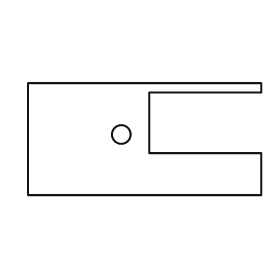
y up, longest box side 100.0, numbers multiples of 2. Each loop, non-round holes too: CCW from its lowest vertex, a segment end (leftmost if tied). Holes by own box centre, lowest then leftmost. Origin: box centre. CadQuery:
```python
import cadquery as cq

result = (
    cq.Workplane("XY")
    .moveTo(-50.0, -24.0)
    .lineTo(50.0, -24.0)
    .lineTo(50.0, -6.0)
    .lineTo(2.0, -6.0)
    .lineTo(2.0, 20.0)
    .lineTo(50.0, 20.0)
    .lineTo(50.0, 24.0)
    .lineTo(-50.0, 24.0)
    .close()
    .moveTo(-10.0, 2.0)
    .circle(4.0)
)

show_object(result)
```